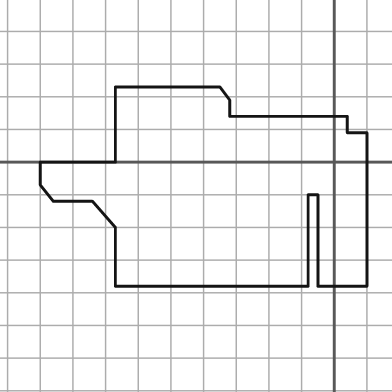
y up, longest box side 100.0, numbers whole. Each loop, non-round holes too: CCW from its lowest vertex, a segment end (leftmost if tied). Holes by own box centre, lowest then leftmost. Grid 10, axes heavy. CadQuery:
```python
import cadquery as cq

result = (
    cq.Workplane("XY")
    .moveTo(-67.0, -38.0)
    .lineTo(-8.0, -38.0)
    .lineTo(-8.0, -10.0)
    .lineTo(-5.0, -10.0)
    .lineTo(-5.0, -38.0)
    .lineTo(10.0, -38.0)
    .lineTo(10.0, 9.0)
    .lineTo(4.0, 9.0)
    .lineTo(4.0, 14.0)
    .lineTo(-32.0, 14.0)
    .lineTo(-32.0, 19.0)
    .lineTo(-35.0, 23.0)
    .lineTo(-67.0, 23.0)
    .lineTo(-67.0, 0.0)
    .lineTo(-90.0, 0.0)
    .lineTo(-90.0, -7.0)
    .lineTo(-86.0, -12.0)
    .lineTo(-74.0, -12.0)
    .lineTo(-67.0, -20.0)
    .close()
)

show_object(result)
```